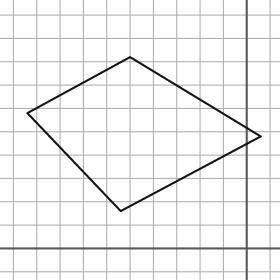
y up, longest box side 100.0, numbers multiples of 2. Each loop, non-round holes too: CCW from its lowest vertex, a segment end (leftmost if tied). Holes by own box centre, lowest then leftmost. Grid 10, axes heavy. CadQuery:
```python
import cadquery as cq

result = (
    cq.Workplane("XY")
    .moveTo(-54.0, 16.0)
    .lineTo(6.0, 48.0)
    .lineTo(-50.0, 82.0)
    .lineTo(-94.0, 58.0)
    .close()
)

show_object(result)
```